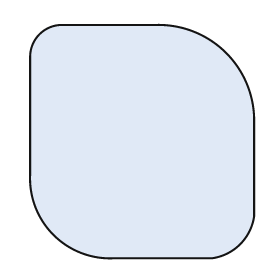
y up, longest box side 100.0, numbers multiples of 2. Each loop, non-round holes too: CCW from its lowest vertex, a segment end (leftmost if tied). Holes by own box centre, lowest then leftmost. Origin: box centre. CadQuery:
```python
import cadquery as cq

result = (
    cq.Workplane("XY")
    .moveTo(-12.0, -50.0)
    .lineTo(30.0, -50.0)
    .threePointArc((42.0, -44.0), (48.0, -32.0))
    .lineTo(48.0, 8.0)
    .threePointArc((36.0, 38.0), (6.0, 50.0))
    .lineTo(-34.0, 50.0)
    .threePointArc((-44.0, 46.0), (-48.0, 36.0))
    .lineTo(-48.0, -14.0)
    .threePointArc((-38.0, -40.0), (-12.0, -50.0))
    .close()
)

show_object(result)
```